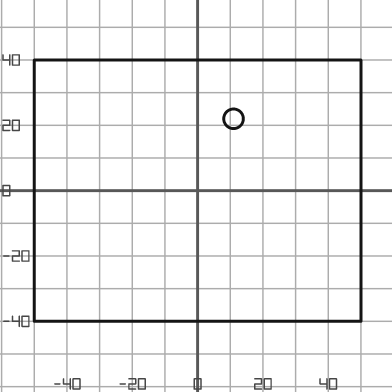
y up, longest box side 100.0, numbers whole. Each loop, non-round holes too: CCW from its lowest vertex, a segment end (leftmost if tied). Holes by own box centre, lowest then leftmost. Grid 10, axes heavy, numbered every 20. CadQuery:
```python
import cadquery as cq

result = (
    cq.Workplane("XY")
    .moveTo(-50.0, -40.0)
    .lineTo(50.0, -40.0)
    .lineTo(50.0, 40.0)
    .lineTo(-50.0, 40.0)
    .close()
    .moveTo(11.0, 22.0)
    .circle(3.0)
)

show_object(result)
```